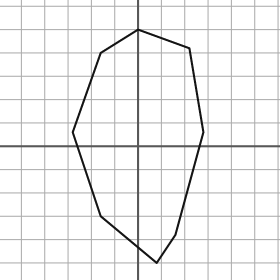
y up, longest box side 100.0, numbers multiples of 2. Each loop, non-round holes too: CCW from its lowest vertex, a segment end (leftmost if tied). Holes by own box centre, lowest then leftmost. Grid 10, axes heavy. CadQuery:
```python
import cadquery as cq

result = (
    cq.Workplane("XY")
    .moveTo(8.0, -50.0)
    .lineTo(16.0, -38.0)
    .lineTo(28.0, 6.0)
    .lineTo(22.0, 42.0)
    .lineTo(0.0, 50.0)
    .lineTo(-16.0, 40.0)
    .lineTo(-28.0, 6.0)
    .lineTo(-16.0, -30.0)
    .close()
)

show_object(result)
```